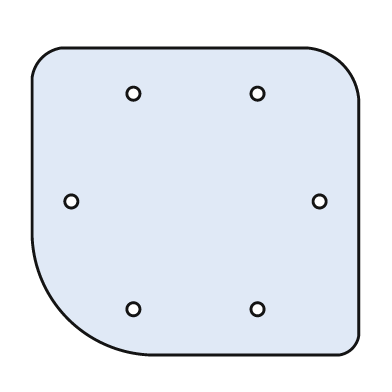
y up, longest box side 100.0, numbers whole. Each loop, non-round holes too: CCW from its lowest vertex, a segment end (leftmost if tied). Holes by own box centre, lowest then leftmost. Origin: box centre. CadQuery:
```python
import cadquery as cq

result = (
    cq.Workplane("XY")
    .moveTo(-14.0, -47.0)
    .lineTo(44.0, -47.0)
    .threePointArc((48.0, -45.0), (50.0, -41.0))
    .lineTo(50.0, 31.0)
    .threePointArc((45.0, 42.0), (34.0, 47.0))
    .lineTo(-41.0, 47.0)
    .threePointArc((-47.0, 44.0), (-50.0, 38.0))
    .lineTo(-50.0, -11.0)
    .threePointArc((-39.0, -36.0), (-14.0, -47.0))
    .close()
    .moveTo(-19.0, -33.0)
    .circle(2.0)
    .moveTo(19.0, -33.0)
    .circle(2.0)
    .moveTo(-38.0, 0.0)
    .circle(2.0)
    .moveTo(38.0, 0.0)
    .circle(2.0)
    .moveTo(-19.0, 33.0)
    .circle(2.0)
    .moveTo(19.0, 33.0)
    .circle(2.0)
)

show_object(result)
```